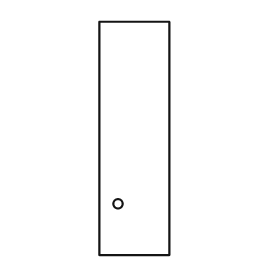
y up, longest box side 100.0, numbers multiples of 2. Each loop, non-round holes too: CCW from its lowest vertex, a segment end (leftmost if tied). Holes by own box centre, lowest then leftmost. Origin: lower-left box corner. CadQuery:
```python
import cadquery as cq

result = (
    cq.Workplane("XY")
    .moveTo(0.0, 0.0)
    .lineTo(30.0, 0.0)
    .lineTo(30.0, 100.0)
    .lineTo(0.0, 100.0)
    .close()
    .moveTo(8.0, 22.0)
    .circle(2.0)
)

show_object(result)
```